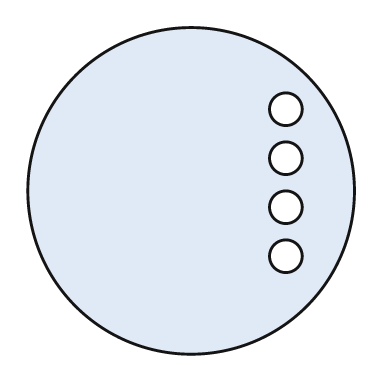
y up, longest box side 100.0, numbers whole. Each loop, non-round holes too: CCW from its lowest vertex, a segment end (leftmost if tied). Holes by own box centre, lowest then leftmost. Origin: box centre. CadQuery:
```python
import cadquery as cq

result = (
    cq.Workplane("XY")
    .moveTo(0.0, 0.0)
    .circle(50.0)
    .moveTo(29.0, -20.0)
    .circle(5.0)
    .moveTo(29.0, -5.0)
    .circle(5.0)
    .moveTo(29.0, 10.0)
    .circle(5.0)
    .moveTo(29.0, 25.0)
    .circle(5.0)
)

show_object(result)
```